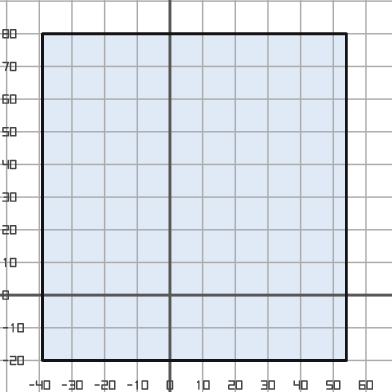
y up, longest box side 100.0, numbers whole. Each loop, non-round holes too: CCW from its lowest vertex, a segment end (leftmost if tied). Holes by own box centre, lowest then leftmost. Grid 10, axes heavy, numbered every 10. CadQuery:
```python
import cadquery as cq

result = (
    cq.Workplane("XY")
    .moveTo(-39.0, -20.0)
    .lineTo(54.0, -20.0)
    .lineTo(54.0, 80.0)
    .lineTo(-39.0, 80.0)
    .close()
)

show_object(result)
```